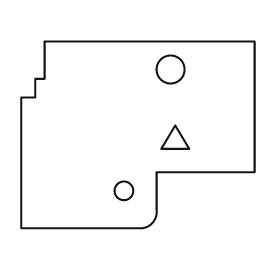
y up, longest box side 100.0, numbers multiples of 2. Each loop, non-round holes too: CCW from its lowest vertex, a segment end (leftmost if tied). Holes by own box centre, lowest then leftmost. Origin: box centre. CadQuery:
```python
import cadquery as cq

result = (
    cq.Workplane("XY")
    .moveTo(-50.0, -40.0)
    .lineTo(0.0, -40.0)
    .threePointArc((6.0, -38.0), (8.0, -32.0))
    .lineTo(8.0, -16.0)
    .lineTo(50.0, -16.0)
    .lineTo(50.0, 40.0)
    .lineTo(-40.0, 40.0)
    .lineTo(-40.0, 24.0)
    .lineTo(-44.0, 24.0)
    .lineTo(-44.0, 16.0)
    .lineTo(-50.0, 16.0)
    .close()
    .moveTo(-6.0, -24.0)
    .circle(4.0)
    .moveTo(10.0, -6.0)
    .lineTo(22.0, -6.0)
    .lineTo(16.0, 4.0)
    .close()
    .moveTo(14.0, 28.0)
    .circle(6.0)
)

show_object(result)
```